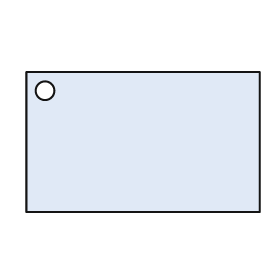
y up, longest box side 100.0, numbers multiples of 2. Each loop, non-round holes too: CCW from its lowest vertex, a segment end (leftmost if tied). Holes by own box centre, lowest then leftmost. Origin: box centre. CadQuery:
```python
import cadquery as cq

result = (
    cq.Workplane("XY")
    .moveTo(-50.0, -30.0)
    .lineTo(50.0, -30.0)
    .lineTo(50.0, 30.0)
    .lineTo(-50.0, 30.0)
    .close()
    .moveTo(-42.0, 22.0)
    .circle(4.0)
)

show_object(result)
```